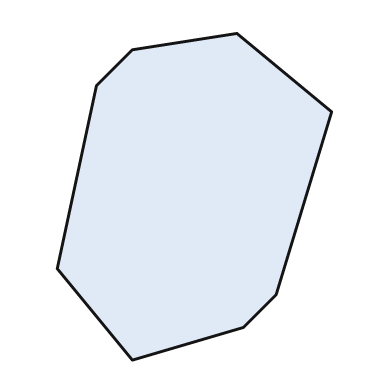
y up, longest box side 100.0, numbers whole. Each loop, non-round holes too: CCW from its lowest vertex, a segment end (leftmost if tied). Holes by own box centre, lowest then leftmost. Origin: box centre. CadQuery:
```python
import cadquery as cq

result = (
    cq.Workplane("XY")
    .moveTo(-19.0, -50.0)
    .lineTo(15.0, -40.0)
    .lineTo(25.0, -30.0)
    .lineTo(42.0, 26.0)
    .lineTo(13.0, 50.0)
    .lineTo(-19.0, 45.0)
    .lineTo(-30.0, 34.0)
    .lineTo(-42.0, -22.0)
    .close()
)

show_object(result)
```